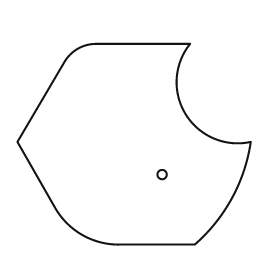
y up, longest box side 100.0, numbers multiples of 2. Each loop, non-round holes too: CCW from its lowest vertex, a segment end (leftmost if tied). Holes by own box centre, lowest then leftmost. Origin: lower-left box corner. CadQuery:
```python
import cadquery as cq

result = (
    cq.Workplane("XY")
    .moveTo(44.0, 0.0)
    .lineTo(76.0, 0.0)
    .threePointArc((92.0, 20.0), (100.0, 44.0))
    .threePointArc((72.0, 56.0), (74.0, 86.0))
    .lineTo(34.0, 86.0)
    .threePointArc((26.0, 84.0), (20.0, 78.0))
    .lineTo(0.0, 44.0)
    .lineTo(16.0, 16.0)
    .threePointArc((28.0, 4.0), (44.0, 0.0))
    .close()
    .moveTo(62.0, 30.0)
    .circle(2.0)
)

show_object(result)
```